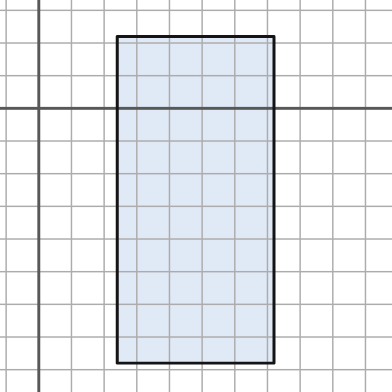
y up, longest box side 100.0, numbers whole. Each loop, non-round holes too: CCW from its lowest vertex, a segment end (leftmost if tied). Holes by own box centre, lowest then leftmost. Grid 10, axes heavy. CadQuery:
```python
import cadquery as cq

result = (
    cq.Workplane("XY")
    .moveTo(24.0, -78.0)
    .lineTo(72.0, -78.0)
    .lineTo(72.0, 22.0)
    .lineTo(24.0, 22.0)
    .close()
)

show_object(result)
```